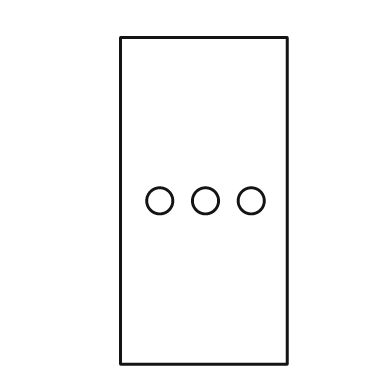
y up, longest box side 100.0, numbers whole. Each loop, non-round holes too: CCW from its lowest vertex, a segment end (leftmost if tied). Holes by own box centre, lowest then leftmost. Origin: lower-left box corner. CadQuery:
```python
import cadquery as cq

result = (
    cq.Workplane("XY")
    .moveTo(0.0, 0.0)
    .lineTo(51.0, 0.0)
    .lineTo(51.0, 100.0)
    .lineTo(0.0, 100.0)
    .close()
    .moveTo(12.0, 50.0)
    .circle(4.0)
    .moveTo(26.0, 50.0)
    .circle(4.0)
    .moveTo(40.0, 50.0)
    .circle(4.0)
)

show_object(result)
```